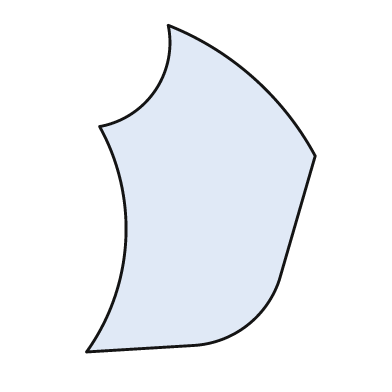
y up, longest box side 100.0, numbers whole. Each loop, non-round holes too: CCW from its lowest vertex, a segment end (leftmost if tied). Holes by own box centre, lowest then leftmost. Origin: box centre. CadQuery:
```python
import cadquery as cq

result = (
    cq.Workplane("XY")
    .moveTo(-35.0, -50.0)
    .lineTo(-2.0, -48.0)
    .threePointArc((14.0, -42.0), (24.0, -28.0))
    .lineTo(35.0, 10.0)
    .threePointArc((16.0, 34.0), (-10.0, 50.0))
    .threePointArc((-14.0, 30.0), (-31.0, 19.0))
    .threePointArc((-23.0, -16.0), (-35.0, -50.0))
    .close()
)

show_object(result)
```